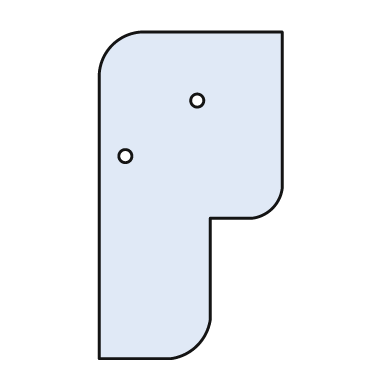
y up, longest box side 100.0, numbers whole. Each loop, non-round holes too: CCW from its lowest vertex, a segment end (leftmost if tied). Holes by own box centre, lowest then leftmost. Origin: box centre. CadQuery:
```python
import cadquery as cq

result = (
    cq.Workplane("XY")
    .moveTo(-28.0, -50.0)
    .lineTo(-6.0, -50.0)
    .threePointArc((2.0, -46.0), (6.0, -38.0))
    .lineTo(6.0, -7.0)
    .lineTo(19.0, -7.0)
    .threePointArc((25.0, -4.0), (28.0, 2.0))
    .lineTo(28.0, 50.0)
    .lineTo(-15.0, 50.0)
    .threePointArc((-24.0, 46.0), (-28.0, 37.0))
    .close()
    .moveTo(-20.0, 12.0)
    .circle(2.0)
    .moveTo(2.0, 29.0)
    .circle(2.0)
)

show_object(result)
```